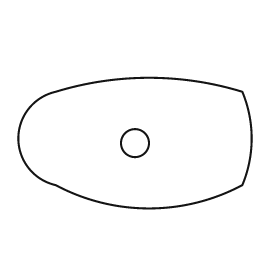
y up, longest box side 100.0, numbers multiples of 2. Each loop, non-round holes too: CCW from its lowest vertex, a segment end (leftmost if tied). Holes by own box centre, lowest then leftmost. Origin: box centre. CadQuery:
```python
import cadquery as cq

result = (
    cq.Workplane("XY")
    .moveTo(-34.0, -18.0)
    .threePointArc((6.0, -28.0), (46.0, -18.0))
    .threePointArc((50.0, 2.0), (46.0, 22.0))
    .threePointArc((6.0, 28.0), (-34.0, 22.0))
    .threePointArc((-50.0, 2.0), (-34.0, -18.0))
    .close()
    .moveTo(0.0, 0.0)
    .circle(6.0)
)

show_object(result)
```